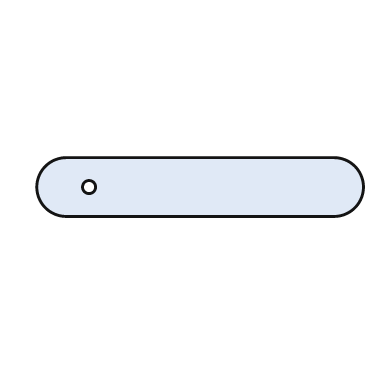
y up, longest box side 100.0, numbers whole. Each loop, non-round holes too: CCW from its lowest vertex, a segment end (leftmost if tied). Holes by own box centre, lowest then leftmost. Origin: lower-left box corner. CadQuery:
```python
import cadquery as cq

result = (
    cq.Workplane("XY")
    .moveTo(9.0, 0.0)
    .lineTo(91.0, 0.0)
    .threePointArc((100.0, 9.0), (91.0, 18.0))
    .lineTo(9.0, 18.0)
    .threePointArc((0.0, 9.0), (9.0, 0.0))
    .close()
    .moveTo(16.0, 9.0)
    .circle(2.0)
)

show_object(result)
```